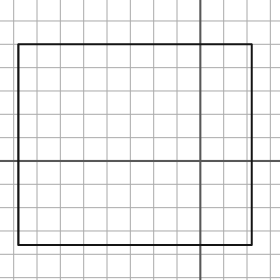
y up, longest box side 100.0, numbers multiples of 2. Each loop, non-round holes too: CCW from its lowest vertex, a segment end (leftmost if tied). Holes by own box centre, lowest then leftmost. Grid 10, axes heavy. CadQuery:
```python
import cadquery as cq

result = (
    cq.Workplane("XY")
    .moveTo(-78.0, -36.0)
    .lineTo(22.0, -36.0)
    .lineTo(22.0, 50.0)
    .lineTo(-78.0, 50.0)
    .close()
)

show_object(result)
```